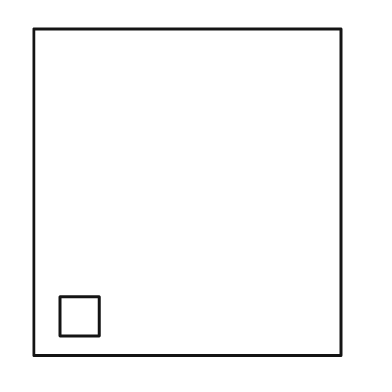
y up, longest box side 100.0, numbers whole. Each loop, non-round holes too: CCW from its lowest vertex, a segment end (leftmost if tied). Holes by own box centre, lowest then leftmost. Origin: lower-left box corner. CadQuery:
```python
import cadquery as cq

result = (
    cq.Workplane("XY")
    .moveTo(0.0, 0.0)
    .lineTo(94.0, 0.0)
    .lineTo(94.0, 100.0)
    .lineTo(0.0, 100.0)
    .close()
    .moveTo(8.0, 6.0)
    .lineTo(20.0, 6.0)
    .lineTo(20.0, 18.0)
    .lineTo(8.0, 18.0)
    .close()
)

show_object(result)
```